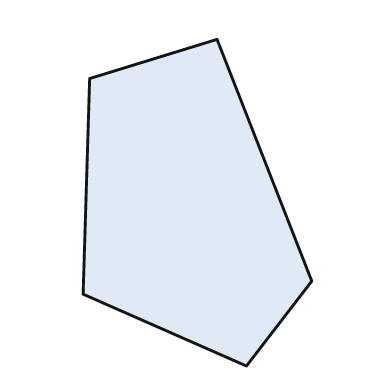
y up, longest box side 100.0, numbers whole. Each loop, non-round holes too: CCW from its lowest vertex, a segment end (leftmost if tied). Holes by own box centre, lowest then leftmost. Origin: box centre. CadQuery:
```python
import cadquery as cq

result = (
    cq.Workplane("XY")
    .moveTo(15.0, -50.0)
    .lineTo(35.0, -24.0)
    .lineTo(6.0, 50.0)
    .lineTo(-33.0, 38.0)
    .lineTo(-35.0, -28.0)
    .close()
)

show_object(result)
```